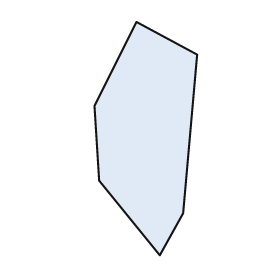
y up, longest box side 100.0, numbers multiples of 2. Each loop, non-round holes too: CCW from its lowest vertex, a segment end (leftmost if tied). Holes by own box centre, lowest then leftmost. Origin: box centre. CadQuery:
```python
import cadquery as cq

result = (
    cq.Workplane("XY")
    .moveTo(6.0, -50.0)
    .lineTo(16.0, -32.0)
    .lineTo(22.0, 36.0)
    .lineTo(-4.0, 50.0)
    .lineTo(-22.0, 14.0)
    .lineTo(-20.0, -18.0)
    .close()
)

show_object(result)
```